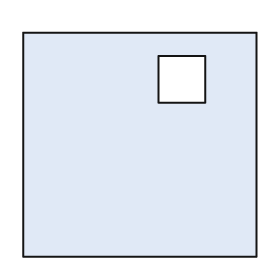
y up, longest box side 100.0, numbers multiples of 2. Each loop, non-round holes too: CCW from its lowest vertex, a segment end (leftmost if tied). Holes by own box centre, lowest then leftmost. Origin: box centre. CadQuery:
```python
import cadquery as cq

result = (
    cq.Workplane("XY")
    .moveTo(-50.0, -48.0)
    .lineTo(50.0, -48.0)
    .lineTo(50.0, 48.0)
    .lineTo(-50.0, 48.0)
    .close()
    .moveTo(8.0, 18.0)
    .lineTo(28.0, 18.0)
    .lineTo(28.0, 38.0)
    .lineTo(8.0, 38.0)
    .close()
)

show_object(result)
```